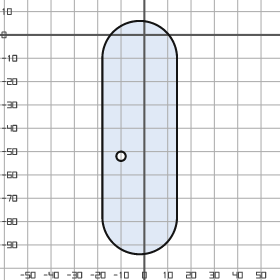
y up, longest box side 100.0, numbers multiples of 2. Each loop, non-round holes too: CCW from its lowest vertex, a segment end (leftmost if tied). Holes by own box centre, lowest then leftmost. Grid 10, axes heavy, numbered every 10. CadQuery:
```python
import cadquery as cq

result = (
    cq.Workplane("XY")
    .moveTo(-18.0, -78.0)
    .threePointArc((-2.0, -94.0), (14.0, -78.0))
    .lineTo(14.0, -10.0)
    .threePointArc((-2.0, 6.0), (-18.0, -10.0))
    .close()
    .moveTo(-10.0, -52.0)
    .circle(2.0)
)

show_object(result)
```